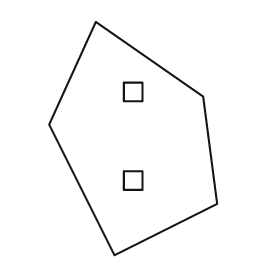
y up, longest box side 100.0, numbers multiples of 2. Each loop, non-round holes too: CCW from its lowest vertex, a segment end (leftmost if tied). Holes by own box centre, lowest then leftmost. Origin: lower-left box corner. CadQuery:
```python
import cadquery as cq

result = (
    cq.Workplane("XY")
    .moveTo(28.0, 0.0)
    .lineTo(72.0, 22.0)
    .lineTo(66.0, 68.0)
    .lineTo(20.0, 100.0)
    .lineTo(0.0, 56.0)
    .close()
    .moveTo(32.0, 28.0)
    .lineTo(40.0, 28.0)
    .lineTo(40.0, 36.0)
    .lineTo(32.0, 36.0)
    .close()
    .moveTo(32.0, 66.0)
    .lineTo(40.0, 66.0)
    .lineTo(40.0, 74.0)
    .lineTo(32.0, 74.0)
    .close()
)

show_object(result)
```